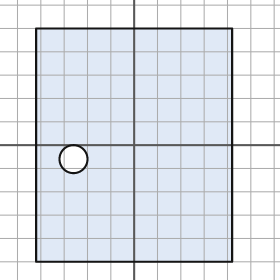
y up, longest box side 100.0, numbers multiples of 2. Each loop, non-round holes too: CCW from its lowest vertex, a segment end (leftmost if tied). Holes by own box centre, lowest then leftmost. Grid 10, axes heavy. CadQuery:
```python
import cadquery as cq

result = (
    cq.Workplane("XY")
    .moveTo(-42.0, -50.0)
    .lineTo(42.0, -50.0)
    .lineTo(42.0, 50.0)
    .lineTo(-42.0, 50.0)
    .close()
    .moveTo(-26.0, -6.0)
    .circle(6.0)
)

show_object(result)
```